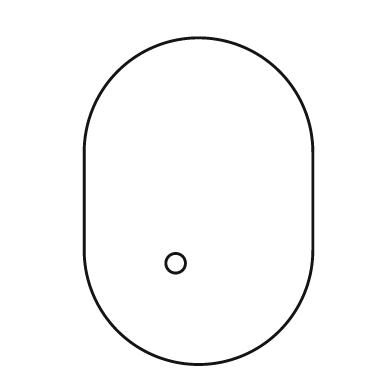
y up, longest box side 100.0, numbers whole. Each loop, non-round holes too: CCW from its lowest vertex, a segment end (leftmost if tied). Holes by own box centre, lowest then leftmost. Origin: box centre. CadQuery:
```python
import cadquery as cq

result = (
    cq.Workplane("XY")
    .moveTo(-35.0, -15.0)
    .threePointArc((0.0, -50.0), (35.0, -15.0))
    .lineTo(35.0, 15.0)
    .threePointArc((0.0, 50.0), (-35.0, 15.0))
    .close()
    .moveTo(-7.0, -19.0)
    .circle(3.0)
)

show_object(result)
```